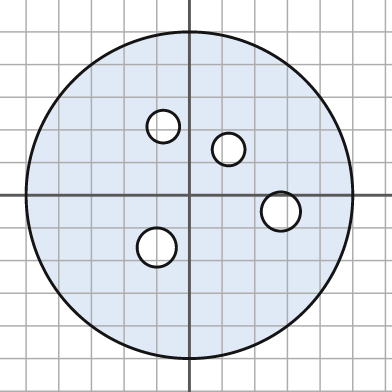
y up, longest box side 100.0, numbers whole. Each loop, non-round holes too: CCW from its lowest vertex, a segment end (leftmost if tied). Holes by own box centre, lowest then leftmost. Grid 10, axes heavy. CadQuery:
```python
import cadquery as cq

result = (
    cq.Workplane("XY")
    .moveTo(0.0, 0.0)
    .circle(50.0)
    .moveTo(-10.0, -16.0)
    .circle(6.0)
    .moveTo(28.0, -5.0)
    .circle(6.0)
    .moveTo(12.0, 14.0)
    .circle(5.0)
    .moveTo(-8.0, 21.0)
    .circle(5.0)
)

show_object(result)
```